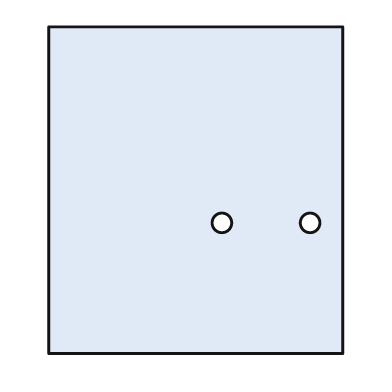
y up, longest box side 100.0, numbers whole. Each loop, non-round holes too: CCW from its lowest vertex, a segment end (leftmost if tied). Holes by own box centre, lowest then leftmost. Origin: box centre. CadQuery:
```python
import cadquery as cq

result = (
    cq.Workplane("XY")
    .moveTo(-45.0, -50.0)
    .lineTo(45.0, -50.0)
    .lineTo(45.0, 50.0)
    .lineTo(-45.0, 50.0)
    .close()
    .moveTo(8.0, -10.0)
    .circle(3.0)
    .moveTo(35.0, -10.0)
    .circle(3.0)
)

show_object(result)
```